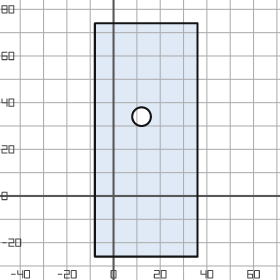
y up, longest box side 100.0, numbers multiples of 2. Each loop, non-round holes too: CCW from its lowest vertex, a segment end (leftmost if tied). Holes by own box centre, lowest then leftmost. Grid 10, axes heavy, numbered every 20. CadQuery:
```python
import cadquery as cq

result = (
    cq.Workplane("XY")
    .moveTo(-8.0, -26.0)
    .lineTo(36.0, -26.0)
    .lineTo(36.0, 74.0)
    .lineTo(-8.0, 74.0)
    .close()
    .moveTo(12.0, 34.0)
    .circle(4.0)
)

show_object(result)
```